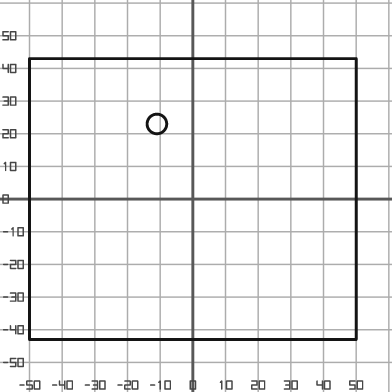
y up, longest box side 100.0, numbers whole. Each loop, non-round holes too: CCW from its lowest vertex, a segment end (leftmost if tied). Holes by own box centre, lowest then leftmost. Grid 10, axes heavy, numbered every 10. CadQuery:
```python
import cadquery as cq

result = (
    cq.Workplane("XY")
    .moveTo(-50.0, -43.0)
    .lineTo(50.0, -43.0)
    .lineTo(50.0, 43.0)
    .lineTo(-50.0, 43.0)
    .close()
    .moveTo(-11.0, 23.0)
    .circle(3.0)
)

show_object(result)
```